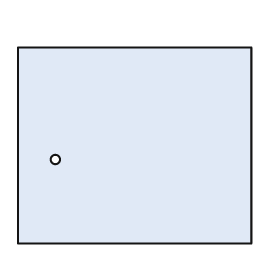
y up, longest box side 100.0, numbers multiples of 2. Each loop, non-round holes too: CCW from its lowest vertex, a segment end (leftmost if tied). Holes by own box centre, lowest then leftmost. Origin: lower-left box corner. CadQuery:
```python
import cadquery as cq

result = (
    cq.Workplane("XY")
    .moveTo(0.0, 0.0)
    .lineTo(100.0, 0.0)
    .lineTo(100.0, 84.0)
    .lineTo(0.0, 84.0)
    .close()
    .moveTo(16.0, 36.0)
    .circle(2.0)
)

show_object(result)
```